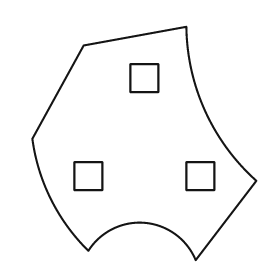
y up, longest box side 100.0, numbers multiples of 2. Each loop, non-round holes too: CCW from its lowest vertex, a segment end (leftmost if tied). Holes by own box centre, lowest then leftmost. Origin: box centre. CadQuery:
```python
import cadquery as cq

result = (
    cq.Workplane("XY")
    .moveTo(22.0, -50.0)
    .lineTo(48.0, -16.0)
    .threePointArc((26.0, 14.0), (18.0, 50.0))
    .lineTo(-26.0, 42.0)
    .lineTo(-48.0, 2.0)
    .threePointArc((-40.0, -24.0), (-24.0, -46.0))
    .threePointArc((0.0, -34.0), (22.0, -50.0))
    .close()
    .moveTo(-30.0, -20.0)
    .lineTo(-18.0, -20.0)
    .lineTo(-18.0, -8.0)
    .lineTo(-30.0, -8.0)
    .close()
    .moveTo(18.0, -20.0)
    .lineTo(30.0, -20.0)
    .lineTo(30.0, -8.0)
    .lineTo(18.0, -8.0)
    .close()
    .moveTo(-6.0, 22.0)
    .lineTo(6.0, 22.0)
    .lineTo(6.0, 34.0)
    .lineTo(-6.0, 34.0)
    .close()
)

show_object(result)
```